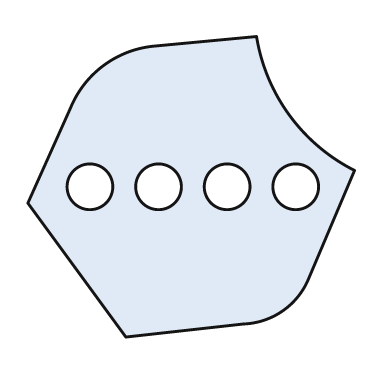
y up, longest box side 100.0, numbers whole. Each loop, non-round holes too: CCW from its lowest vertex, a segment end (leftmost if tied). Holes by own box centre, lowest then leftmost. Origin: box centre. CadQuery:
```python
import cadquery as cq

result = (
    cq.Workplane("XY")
    .moveTo(-20.0, -46.0)
    .lineTo(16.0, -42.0)
    .threePointArc((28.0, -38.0), (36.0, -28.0))
    .lineTo(50.0, 5.0)
    .threePointArc((30.0, 22.0), (20.0, 46.0))
    .lineTo(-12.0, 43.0)
    .threePointArc((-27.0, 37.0), (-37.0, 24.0))
    .lineTo(-50.0, -5.0)
    .close()
    .moveTo(-31.0, 0.0)
    .circle(7.0)
    .moveTo(-10.0, 0.0)
    .circle(7.0)
    .moveTo(11.0, 0.0)
    .circle(7.0)
    .moveTo(32.0, 0.0)
    .circle(7.0)
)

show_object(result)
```